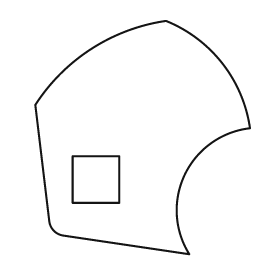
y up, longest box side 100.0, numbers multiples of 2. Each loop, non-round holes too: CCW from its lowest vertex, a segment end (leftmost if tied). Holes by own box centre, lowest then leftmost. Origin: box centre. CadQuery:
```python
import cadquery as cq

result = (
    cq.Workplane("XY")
    .moveTo(20.0, -50.0)
    .threePointArc((18.0, -16.0), (46.0, 4.0))
    .threePointArc((34.0, 32.0), (10.0, 50.0))
    .threePointArc((-22.0, 38.0), (-46.0, 14.0))
    .lineTo(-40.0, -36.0)
    .threePointArc((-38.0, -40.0), (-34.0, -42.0))
    .close()
    .moveTo(-30.0, -28.0)
    .lineTo(-10.0, -28.0)
    .lineTo(-10.0, -8.0)
    .lineTo(-30.0, -8.0)
    .close()
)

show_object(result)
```